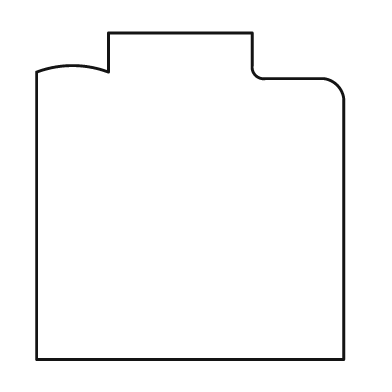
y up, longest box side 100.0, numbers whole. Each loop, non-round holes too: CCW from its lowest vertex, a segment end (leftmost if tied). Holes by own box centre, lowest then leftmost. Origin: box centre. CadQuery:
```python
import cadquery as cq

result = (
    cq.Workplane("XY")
    .moveTo(-47.0, -50.0)
    .lineTo(47.0, -50.0)
    .lineTo(47.0, 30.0)
    .threePointArc((45.0, 34.0), (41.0, 36.0))
    .lineTo(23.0, 36.0)
    .threePointArc((20.0, 37.0), (19.0, 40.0))
    .lineTo(19.0, 50.0)
    .lineTo(-25.0, 50.0)
    .lineTo(-25.0, 38.0)
    .threePointArc((-36.0, 40.0), (-47.0, 38.0))
    .close()
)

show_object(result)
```